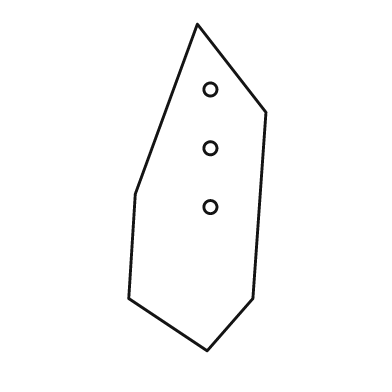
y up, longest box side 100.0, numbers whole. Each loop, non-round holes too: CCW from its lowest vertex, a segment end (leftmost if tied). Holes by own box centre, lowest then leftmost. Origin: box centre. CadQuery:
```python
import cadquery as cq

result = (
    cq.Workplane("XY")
    .moveTo(3.0, -50.0)
    .lineTo(17.0, -34.0)
    .lineTo(21.0, 23.0)
    .lineTo(0.0, 50.0)
    .lineTo(-19.0, -2.0)
    .lineTo(-21.0, -34.0)
    .close()
    .moveTo(4.0, -6.0)
    .circle(2.0)
    .moveTo(4.0, 12.0)
    .circle(2.0)
    .moveTo(4.0, 30.0)
    .circle(2.0)
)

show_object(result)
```